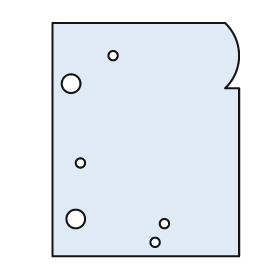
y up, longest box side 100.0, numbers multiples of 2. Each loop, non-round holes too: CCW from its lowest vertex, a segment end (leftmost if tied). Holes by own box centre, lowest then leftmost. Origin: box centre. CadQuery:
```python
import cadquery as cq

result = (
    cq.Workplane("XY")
    .moveTo(-40.0, -50.0)
    .lineTo(40.0, -50.0)
    .lineTo(40.0, 22.0)
    .lineTo(34.0, 22.0)
    .threePointArc((40.0, 36.0), (34.0, 50.0))
    .lineTo(-40.0, 50.0)
    .close()
    .moveTo(4.0, -44.0)
    .circle(2.0)
    .moveTo(8.0, -36.0)
    .circle(2.0)
    .moveTo(-30.0, -34.0)
    .circle(4.0)
    .moveTo(-28.0, -10.0)
    .circle(2.0)
    .moveTo(-32.0, 24.0)
    .circle(4.0)
    .moveTo(-14.0, 36.0)
    .circle(2.0)
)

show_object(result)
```